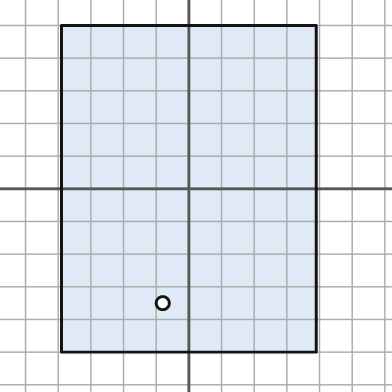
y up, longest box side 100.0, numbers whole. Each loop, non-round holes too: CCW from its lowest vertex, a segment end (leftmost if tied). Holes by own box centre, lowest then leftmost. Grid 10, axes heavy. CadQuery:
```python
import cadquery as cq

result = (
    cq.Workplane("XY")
    .moveTo(-39.0, -50.0)
    .lineTo(39.0, -50.0)
    .lineTo(39.0, 50.0)
    .lineTo(-39.0, 50.0)
    .close()
    .moveTo(-8.0, -35.0)
    .circle(2.0)
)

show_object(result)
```